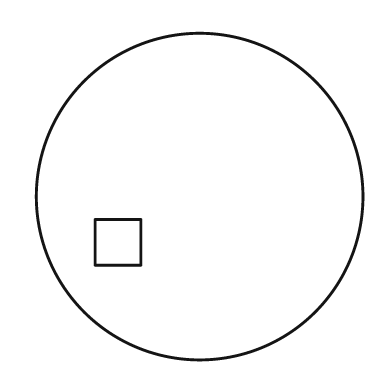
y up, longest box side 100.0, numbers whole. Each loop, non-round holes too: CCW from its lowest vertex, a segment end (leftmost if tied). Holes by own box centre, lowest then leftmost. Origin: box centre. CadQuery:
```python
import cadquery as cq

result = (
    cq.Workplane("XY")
    .moveTo(0.0, 0.0)
    .circle(50.0)
    .moveTo(-32.0, -21.0)
    .lineTo(-18.0, -21.0)
    .lineTo(-18.0, -7.0)
    .lineTo(-32.0, -7.0)
    .close()
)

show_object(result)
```